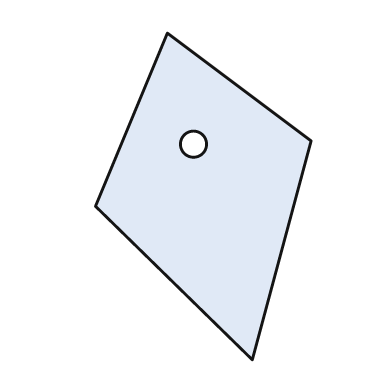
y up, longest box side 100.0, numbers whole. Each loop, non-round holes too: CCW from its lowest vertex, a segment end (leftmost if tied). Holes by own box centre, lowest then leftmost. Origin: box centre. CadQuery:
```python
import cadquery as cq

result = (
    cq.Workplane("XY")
    .moveTo(15.0, -50.0)
    .lineTo(33.0, 17.0)
    .lineTo(-11.0, 50.0)
    .lineTo(-33.0, -3.0)
    .close()
    .moveTo(-3.0, 16.0)
    .circle(4.0)
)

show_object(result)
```